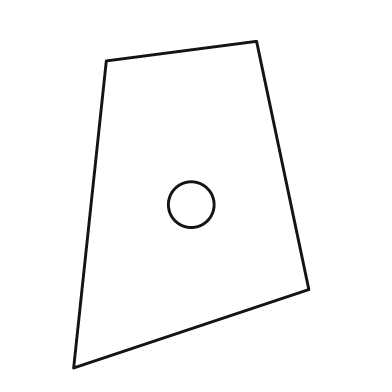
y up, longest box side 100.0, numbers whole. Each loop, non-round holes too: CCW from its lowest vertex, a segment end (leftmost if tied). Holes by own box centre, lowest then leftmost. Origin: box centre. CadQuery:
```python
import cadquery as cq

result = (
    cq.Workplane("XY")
    .moveTo(-36.0, -50.0)
    .lineTo(36.0, -26.0)
    .lineTo(20.0, 50.0)
    .lineTo(-26.0, 44.0)
    .close()
    .moveTo(0.0, 0.0)
    .circle(7.0)
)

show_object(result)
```